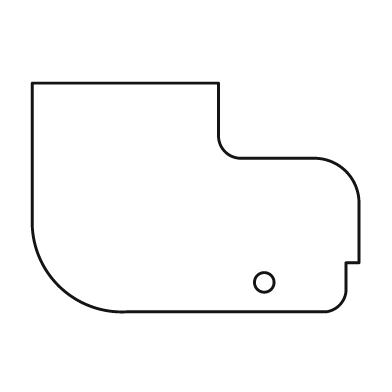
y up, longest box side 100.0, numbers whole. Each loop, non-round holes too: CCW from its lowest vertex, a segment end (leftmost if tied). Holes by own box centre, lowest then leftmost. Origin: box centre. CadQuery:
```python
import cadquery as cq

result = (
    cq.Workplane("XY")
    .moveTo(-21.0, -35.0)
    .lineTo(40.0, -35.0)
    .threePointArc((44.0, -33.0), (46.0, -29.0))
    .lineTo(46.0, -20.0)
    .lineTo(50.0, -20.0)
    .lineTo(50.0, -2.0)
    .threePointArc((46.0, 8.0), (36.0, 12.0))
    .lineTo(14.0, 12.0)
    .threePointArc((9.0, 14.0), (7.0, 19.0))
    .lineTo(7.0, 35.0)
    .lineTo(-50.0, 35.0)
    .lineTo(-50.0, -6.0)
    .threePointArc((-42.0, -27.0), (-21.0, -35.0))
    .close()
    .moveTo(21.0, -26.0)
    .circle(3.0)
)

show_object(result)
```